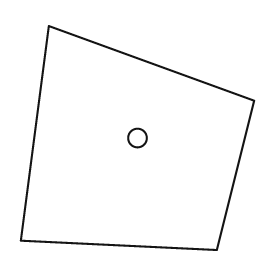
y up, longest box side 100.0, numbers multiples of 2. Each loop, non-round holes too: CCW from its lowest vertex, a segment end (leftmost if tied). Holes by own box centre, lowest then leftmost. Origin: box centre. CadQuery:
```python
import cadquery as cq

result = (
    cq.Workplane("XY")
    .moveTo(34.0, -48.0)
    .lineTo(50.0, 16.0)
    .lineTo(-38.0, 48.0)
    .lineTo(-50.0, -44.0)
    .close()
    .moveTo(0.0, 0.0)
    .circle(4.0)
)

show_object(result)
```